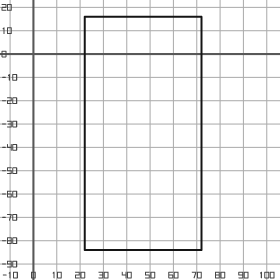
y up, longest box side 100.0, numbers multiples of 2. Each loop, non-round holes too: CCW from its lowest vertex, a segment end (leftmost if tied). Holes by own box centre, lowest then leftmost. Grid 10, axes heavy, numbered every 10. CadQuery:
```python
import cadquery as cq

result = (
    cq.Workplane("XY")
    .moveTo(22.0, -84.0)
    .lineTo(72.0, -84.0)
    .lineTo(72.0, 16.0)
    .lineTo(22.0, 16.0)
    .close()
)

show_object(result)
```